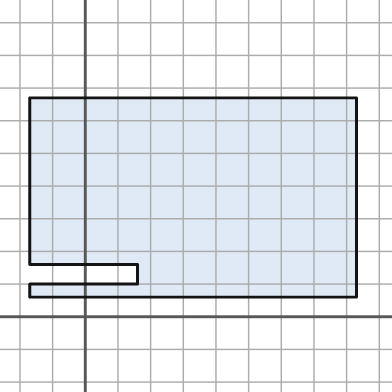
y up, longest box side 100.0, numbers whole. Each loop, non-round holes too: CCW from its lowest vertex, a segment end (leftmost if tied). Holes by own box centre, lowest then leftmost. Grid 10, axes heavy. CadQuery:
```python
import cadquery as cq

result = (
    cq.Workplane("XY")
    .moveTo(-17.0, 6.0)
    .lineTo(83.0, 6.0)
    .lineTo(83.0, 67.0)
    .lineTo(-17.0, 67.0)
    .lineTo(-17.0, 16.0)
    .lineTo(16.0, 16.0)
    .lineTo(16.0, 10.0)
    .lineTo(-17.0, 10.0)
    .close()
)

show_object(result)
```